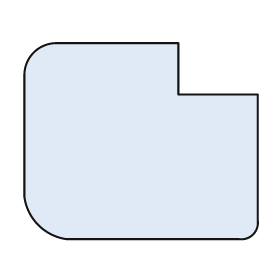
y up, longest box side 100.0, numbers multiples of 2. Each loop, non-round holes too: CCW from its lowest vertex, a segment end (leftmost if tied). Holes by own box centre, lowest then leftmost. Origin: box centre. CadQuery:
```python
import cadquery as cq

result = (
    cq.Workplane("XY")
    .moveTo(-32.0, -42.0)
    .lineTo(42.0, -42.0)
    .threePointArc((48.0, -40.0), (50.0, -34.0))
    .lineTo(50.0, 20.0)
    .lineTo(16.0, 20.0)
    .lineTo(16.0, 42.0)
    .lineTo(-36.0, 42.0)
    .threePointArc((-46.0, 38.0), (-50.0, 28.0))
    .lineTo(-50.0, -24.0)
    .threePointArc((-44.0, -36.0), (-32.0, -42.0))
    .close()
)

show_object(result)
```